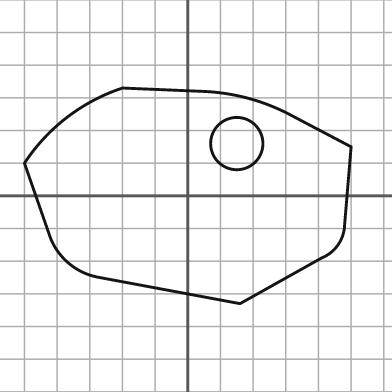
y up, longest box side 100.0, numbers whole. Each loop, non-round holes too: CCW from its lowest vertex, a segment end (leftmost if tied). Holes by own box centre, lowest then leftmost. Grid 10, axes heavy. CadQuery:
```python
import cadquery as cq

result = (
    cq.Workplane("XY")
    .moveTo(16.0, -33.0)
    .lineTo(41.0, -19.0)
    .threePointArc((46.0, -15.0), (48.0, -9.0))
    .lineTo(50.0, 15.0)
    .lineTo(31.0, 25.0)
    .threePointArc((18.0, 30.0), (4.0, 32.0))
    .lineTo(-20.0, 33.0)
    .threePointArc((-37.0, 24.0), (-50.0, 10.0))
    .lineTo(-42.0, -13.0)
    .threePointArc((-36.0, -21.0), (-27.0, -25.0))
    .close()
    .moveTo(15.0, 16.0)
    .circle(8.0)
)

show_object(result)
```